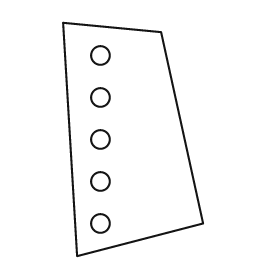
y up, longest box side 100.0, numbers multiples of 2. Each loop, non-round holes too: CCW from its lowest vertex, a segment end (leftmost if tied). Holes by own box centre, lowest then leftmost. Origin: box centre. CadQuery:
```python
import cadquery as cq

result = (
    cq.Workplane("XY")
    .moveTo(-24.0, -50.0)
    .lineTo(30.0, -36.0)
    .lineTo(12.0, 46.0)
    .lineTo(-30.0, 50.0)
    .close()
    .moveTo(-14.0, -36.0)
    .circle(4.0)
    .moveTo(-14.0, -18.0)
    .circle(4.0)
    .moveTo(-14.0, 0.0)
    .circle(4.0)
    .moveTo(-14.0, 18.0)
    .circle(4.0)
    .moveTo(-14.0, 36.0)
    .circle(4.0)
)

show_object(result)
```